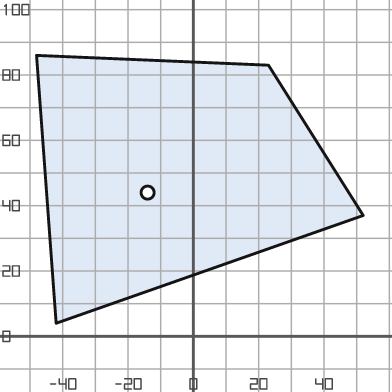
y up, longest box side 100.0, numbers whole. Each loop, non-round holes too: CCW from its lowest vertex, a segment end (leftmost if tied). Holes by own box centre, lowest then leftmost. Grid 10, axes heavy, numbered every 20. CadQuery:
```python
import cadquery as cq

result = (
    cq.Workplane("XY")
    .moveTo(-42.0, 4.0)
    .lineTo(52.0, 37.0)
    .lineTo(23.0, 83.0)
    .lineTo(-48.0, 86.0)
    .close()
    .moveTo(-14.0, 44.0)
    .circle(2.0)
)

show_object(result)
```